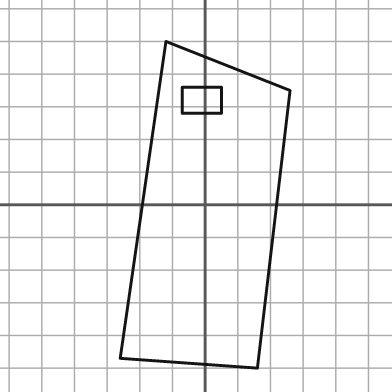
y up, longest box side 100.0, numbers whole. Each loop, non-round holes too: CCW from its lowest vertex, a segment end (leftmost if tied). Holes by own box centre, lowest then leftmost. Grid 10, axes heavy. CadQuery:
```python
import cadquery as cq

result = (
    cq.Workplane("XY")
    .moveTo(16.0, -50.0)
    .lineTo(26.0, 35.0)
    .lineTo(-12.0, 50.0)
    .lineTo(-26.0, -47.0)
    .close()
    .moveTo(-7.0, 28.0)
    .lineTo(5.0, 28.0)
    .lineTo(5.0, 36.0)
    .lineTo(-7.0, 36.0)
    .close()
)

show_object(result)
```